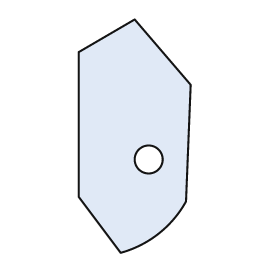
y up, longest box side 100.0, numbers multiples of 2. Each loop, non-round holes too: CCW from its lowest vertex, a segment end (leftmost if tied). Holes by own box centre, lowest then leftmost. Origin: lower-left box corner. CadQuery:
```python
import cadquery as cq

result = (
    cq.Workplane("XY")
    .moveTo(18.0, 0.0)
    .threePointArc((34.0, 8.0), (46.0, 22.0))
    .lineTo(48.0, 72.0)
    .lineTo(24.0, 100.0)
    .lineTo(0.0, 86.0)
    .lineTo(0.0, 24.0)
    .close()
    .moveTo(30.0, 40.0)
    .circle(6.0)
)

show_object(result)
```